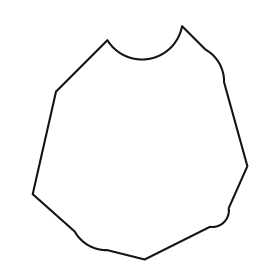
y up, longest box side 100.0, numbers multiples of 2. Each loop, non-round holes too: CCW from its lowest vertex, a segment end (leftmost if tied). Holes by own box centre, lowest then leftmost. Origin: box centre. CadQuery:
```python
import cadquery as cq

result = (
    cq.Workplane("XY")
    .moveTo(2.0, -50.0)
    .lineTo(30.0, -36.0)
    .threePointArc((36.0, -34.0), (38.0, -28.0))
    .lineTo(46.0, -10.0)
    .lineTo(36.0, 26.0)
    .threePointArc((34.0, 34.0), (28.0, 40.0))
    .lineTo(18.0, 50.0)
    .threePointArc((4.0, 36.0), (-14.0, 44.0))
    .lineTo(-36.0, 22.0)
    .lineTo(-46.0, -22.0)
    .lineTo(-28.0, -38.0)
    .threePointArc((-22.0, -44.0), (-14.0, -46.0))
    .close()
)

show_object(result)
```